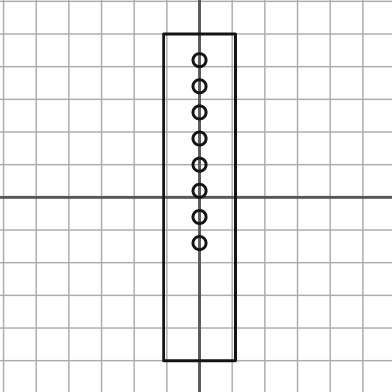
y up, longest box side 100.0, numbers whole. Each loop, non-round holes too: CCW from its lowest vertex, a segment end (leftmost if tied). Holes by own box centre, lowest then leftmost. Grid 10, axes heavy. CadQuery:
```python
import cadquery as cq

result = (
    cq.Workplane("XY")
    .moveTo(-11.0, -50.0)
    .lineTo(11.0, -50.0)
    .lineTo(11.0, 50.0)
    .lineTo(-11.0, 50.0)
    .close()
    .moveTo(0.0, -14.0)
    .circle(2.0)
    .moveTo(0.0, -6.0)
    .circle(2.0)
    .moveTo(0.0, 2.0)
    .circle(2.0)
    .moveTo(0.0, 10.0)
    .circle(2.0)
    .moveTo(0.0, 18.0)
    .circle(2.0)
    .moveTo(0.0, 26.0)
    .circle(2.0)
    .moveTo(0.0, 34.0)
    .circle(2.0)
    .moveTo(0.0, 42.0)
    .circle(2.0)
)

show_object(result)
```